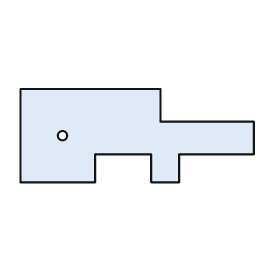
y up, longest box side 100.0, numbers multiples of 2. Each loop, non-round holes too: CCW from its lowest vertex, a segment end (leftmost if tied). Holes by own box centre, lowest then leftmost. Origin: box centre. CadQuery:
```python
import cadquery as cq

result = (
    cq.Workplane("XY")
    .moveTo(-50.0, -20.0)
    .lineTo(-18.0, -20.0)
    .lineTo(-18.0, -8.0)
    .lineTo(6.0, -8.0)
    .lineTo(6.0, -20.0)
    .lineTo(18.0, -20.0)
    .lineTo(18.0, -8.0)
    .lineTo(50.0, -8.0)
    .lineTo(50.0, 6.0)
    .lineTo(10.0, 6.0)
    .lineTo(10.0, 20.0)
    .lineTo(-50.0, 20.0)
    .close()
    .moveTo(-32.0, 0.0)
    .circle(2.0)
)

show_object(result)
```